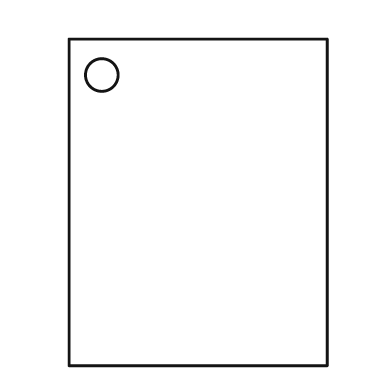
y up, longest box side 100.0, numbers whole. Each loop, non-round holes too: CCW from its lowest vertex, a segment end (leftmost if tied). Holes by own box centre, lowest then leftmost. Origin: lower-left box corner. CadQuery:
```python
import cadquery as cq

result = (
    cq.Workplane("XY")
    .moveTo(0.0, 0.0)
    .lineTo(79.0, 0.0)
    .lineTo(79.0, 100.0)
    .lineTo(0.0, 100.0)
    .close()
    .moveTo(10.0, 89.0)
    .circle(5.0)
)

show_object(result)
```